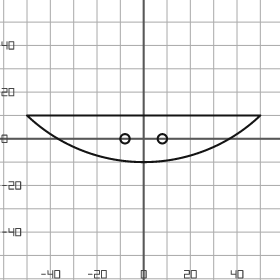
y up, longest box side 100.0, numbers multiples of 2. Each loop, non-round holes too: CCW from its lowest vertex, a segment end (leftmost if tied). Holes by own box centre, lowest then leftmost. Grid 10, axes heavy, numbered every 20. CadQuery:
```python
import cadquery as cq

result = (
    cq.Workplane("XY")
    .moveTo(-50.0, 10.0)
    .threePointArc((0.0, -10.0), (50.0, 10.0))
    .close()
    .moveTo(-8.0, 0.0)
    .circle(2.0)
    .moveTo(8.0, 0.0)
    .circle(2.0)
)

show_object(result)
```